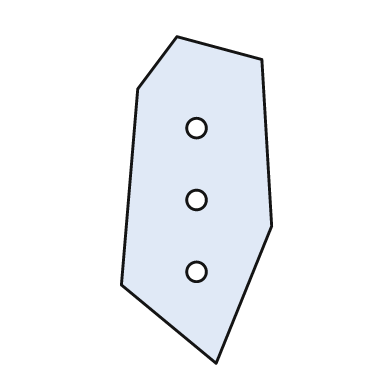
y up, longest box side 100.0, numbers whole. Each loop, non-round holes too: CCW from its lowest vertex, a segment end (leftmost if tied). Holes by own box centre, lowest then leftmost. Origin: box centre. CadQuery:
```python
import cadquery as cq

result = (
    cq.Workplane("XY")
    .moveTo(6.0, -50.0)
    .lineTo(23.0, -8.0)
    .lineTo(20.0, 43.0)
    .lineTo(-6.0, 50.0)
    .lineTo(-18.0, 34.0)
    .lineTo(-23.0, -26.0)
    .close()
    .moveTo(0.0, -22.0)
    .circle(3.0)
    .moveTo(0.0, 0.0)
    .circle(3.0)
    .moveTo(0.0, 22.0)
    .circle(3.0)
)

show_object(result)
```